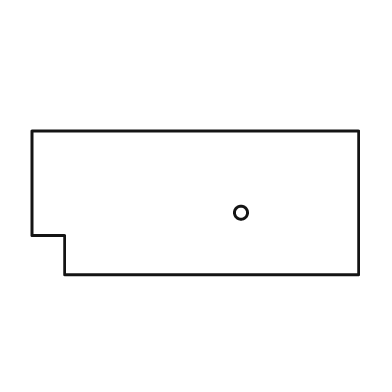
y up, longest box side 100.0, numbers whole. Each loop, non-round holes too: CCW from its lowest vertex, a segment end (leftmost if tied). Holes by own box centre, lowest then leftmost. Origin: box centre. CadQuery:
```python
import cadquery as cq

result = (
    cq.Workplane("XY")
    .moveTo(-40.0, -22.0)
    .lineTo(50.0, -22.0)
    .lineTo(50.0, 22.0)
    .lineTo(-50.0, 22.0)
    .lineTo(-50.0, -10.0)
    .lineTo(-40.0, -10.0)
    .close()
    .moveTo(14.0, -3.0)
    .circle(2.0)
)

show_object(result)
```